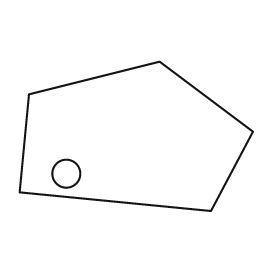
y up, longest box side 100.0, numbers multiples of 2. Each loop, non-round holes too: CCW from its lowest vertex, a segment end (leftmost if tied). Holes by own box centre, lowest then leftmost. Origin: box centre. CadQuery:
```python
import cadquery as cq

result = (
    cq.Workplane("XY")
    .moveTo(32.0, -32.0)
    .lineTo(50.0, 2.0)
    .lineTo(10.0, 32.0)
    .lineTo(-46.0, 18.0)
    .lineTo(-50.0, -24.0)
    .close()
    .moveTo(-30.0, -16.0)
    .circle(6.0)
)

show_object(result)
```